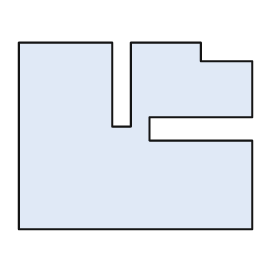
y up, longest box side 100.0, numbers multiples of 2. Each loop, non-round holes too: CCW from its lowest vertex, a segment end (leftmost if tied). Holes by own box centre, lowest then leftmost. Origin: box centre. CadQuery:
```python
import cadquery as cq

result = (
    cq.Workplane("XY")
    .moveTo(-50.0, -40.0)
    .lineTo(50.0, -40.0)
    .lineTo(50.0, -2.0)
    .lineTo(6.0, -2.0)
    .lineTo(6.0, 8.0)
    .lineTo(50.0, 8.0)
    .lineTo(50.0, 32.0)
    .lineTo(28.0, 32.0)
    .lineTo(28.0, 40.0)
    .lineTo(-2.0, 40.0)
    .lineTo(-2.0, 4.0)
    .lineTo(-10.0, 4.0)
    .lineTo(-10.0, 40.0)
    .lineTo(-50.0, 40.0)
    .close()
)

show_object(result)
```